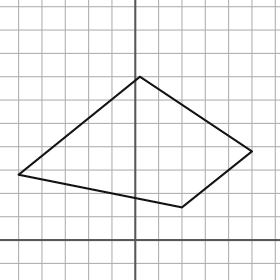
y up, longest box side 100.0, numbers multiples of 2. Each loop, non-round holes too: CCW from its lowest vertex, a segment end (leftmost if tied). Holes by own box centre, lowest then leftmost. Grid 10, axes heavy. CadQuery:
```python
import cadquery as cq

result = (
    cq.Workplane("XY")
    .moveTo(20.0, 14.0)
    .lineTo(50.0, 38.0)
    .lineTo(2.0, 70.0)
    .lineTo(-50.0, 28.0)
    .close()
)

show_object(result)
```